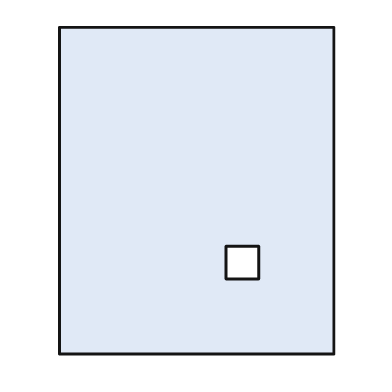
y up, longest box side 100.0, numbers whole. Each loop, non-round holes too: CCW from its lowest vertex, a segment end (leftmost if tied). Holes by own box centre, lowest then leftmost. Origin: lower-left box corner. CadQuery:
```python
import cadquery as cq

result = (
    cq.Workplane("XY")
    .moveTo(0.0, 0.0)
    .lineTo(84.0, 0.0)
    .lineTo(84.0, 100.0)
    .lineTo(0.0, 100.0)
    .close()
    .moveTo(51.0, 23.0)
    .lineTo(61.0, 23.0)
    .lineTo(61.0, 33.0)
    .lineTo(51.0, 33.0)
    .close()
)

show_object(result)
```